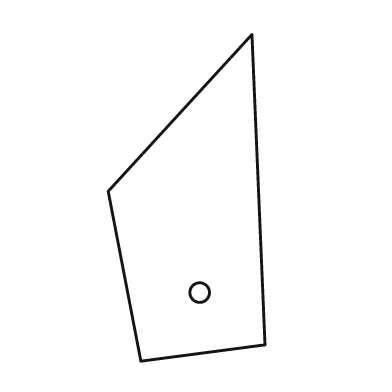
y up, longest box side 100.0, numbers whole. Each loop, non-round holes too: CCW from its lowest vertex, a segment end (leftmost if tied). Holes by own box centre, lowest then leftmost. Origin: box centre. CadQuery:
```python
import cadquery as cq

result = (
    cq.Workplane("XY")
    .moveTo(-14.0, -50.0)
    .lineTo(24.0, -45.0)
    .lineTo(20.0, 50.0)
    .lineTo(-24.0, 2.0)
    .close()
    .moveTo(4.0, -29.0)
    .circle(3.0)
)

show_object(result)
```